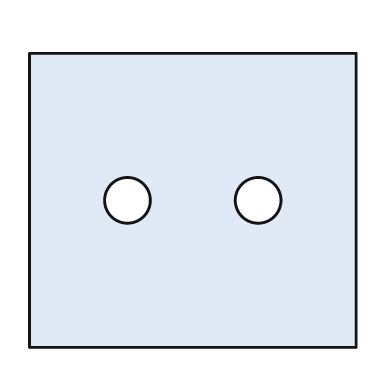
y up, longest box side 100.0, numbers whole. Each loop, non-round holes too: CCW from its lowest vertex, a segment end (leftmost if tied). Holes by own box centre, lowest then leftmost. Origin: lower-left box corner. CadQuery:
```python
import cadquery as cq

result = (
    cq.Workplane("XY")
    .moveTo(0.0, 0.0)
    .lineTo(100.0, 0.0)
    .lineTo(100.0, 90.0)
    .lineTo(0.0, 90.0)
    .close()
    .moveTo(30.0, 45.0)
    .circle(7.0)
    .moveTo(70.0, 45.0)
    .circle(7.0)
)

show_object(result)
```